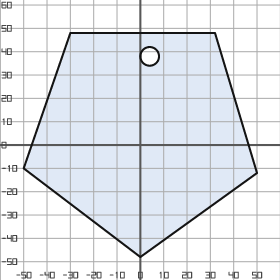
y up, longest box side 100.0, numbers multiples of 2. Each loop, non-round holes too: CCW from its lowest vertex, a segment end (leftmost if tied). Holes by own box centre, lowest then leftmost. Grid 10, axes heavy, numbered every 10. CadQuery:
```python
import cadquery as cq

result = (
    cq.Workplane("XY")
    .moveTo(0.0, -48.0)
    .lineTo(50.0, -12.0)
    .lineTo(32.0, 48.0)
    .lineTo(-30.0, 48.0)
    .lineTo(-50.0, -10.0)
    .close()
    .moveTo(4.0, 38.0)
    .circle(4.0)
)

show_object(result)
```